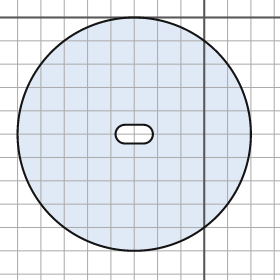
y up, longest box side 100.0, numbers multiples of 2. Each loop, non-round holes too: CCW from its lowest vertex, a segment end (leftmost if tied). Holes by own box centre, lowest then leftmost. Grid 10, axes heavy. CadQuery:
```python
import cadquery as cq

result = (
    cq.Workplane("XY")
    .moveTo(-30.0, -50.0)
    .circle(50.0)
    .moveTo(-34.0, -54.0)
    .lineTo(-26.0, -54.0)
    .threePointArc((-22.0, -50.0), (-26.0, -46.0))
    .lineTo(-34.0, -46.0)
    .threePointArc((-38.0, -50.0), (-34.0, -54.0))
    .close()
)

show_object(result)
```